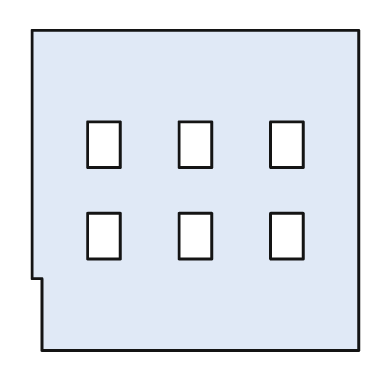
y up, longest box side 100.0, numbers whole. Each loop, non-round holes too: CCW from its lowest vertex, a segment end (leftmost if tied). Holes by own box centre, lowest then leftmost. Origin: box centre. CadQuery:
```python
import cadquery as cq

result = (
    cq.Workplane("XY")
    .moveTo(-47.0, -49.0)
    .lineTo(50.0, -49.0)
    .lineTo(50.0, 49.0)
    .lineTo(-50.0, 49.0)
    .lineTo(-50.0, -27.0)
    .lineTo(-47.0, -27.0)
    .close()
    .moveTo(-33.0, -21.0)
    .lineTo(-23.0, -21.0)
    .lineTo(-23.0, -7.0)
    .lineTo(-33.0, -7.0)
    .close()
    .moveTo(-5.0, -21.0)
    .lineTo(5.0, -21.0)
    .lineTo(5.0, -7.0)
    .lineTo(-5.0, -7.0)
    .close()
    .moveTo(23.0, -21.0)
    .lineTo(33.0, -21.0)
    .lineTo(33.0, -7.0)
    .lineTo(23.0, -7.0)
    .close()
    .moveTo(-33.0, 7.0)
    .lineTo(-23.0, 7.0)
    .lineTo(-23.0, 21.0)
    .lineTo(-33.0, 21.0)
    .close()
    .moveTo(-5.0, 7.0)
    .lineTo(5.0, 7.0)
    .lineTo(5.0, 21.0)
    .lineTo(-5.0, 21.0)
    .close()
    .moveTo(23.0, 7.0)
    .lineTo(33.0, 7.0)
    .lineTo(33.0, 21.0)
    .lineTo(23.0, 21.0)
    .close()
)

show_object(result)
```